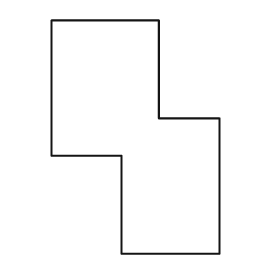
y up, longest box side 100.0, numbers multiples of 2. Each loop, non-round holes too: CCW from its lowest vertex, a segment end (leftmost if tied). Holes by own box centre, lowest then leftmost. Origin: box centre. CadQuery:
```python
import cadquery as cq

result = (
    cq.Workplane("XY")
    .moveTo(-6.0, -50.0)
    .lineTo(36.0, -50.0)
    .lineTo(36.0, 8.0)
    .lineTo(10.0, 8.0)
    .lineTo(10.0, 50.0)
    .lineTo(-36.0, 50.0)
    .lineTo(-36.0, -8.0)
    .lineTo(-6.0, -8.0)
    .close()
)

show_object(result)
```